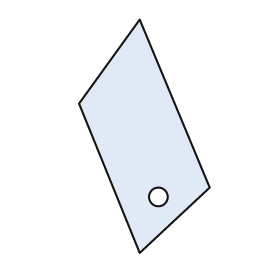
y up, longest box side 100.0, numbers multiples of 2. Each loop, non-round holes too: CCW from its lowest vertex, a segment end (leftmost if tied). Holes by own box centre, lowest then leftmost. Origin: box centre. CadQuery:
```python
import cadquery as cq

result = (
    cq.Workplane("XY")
    .moveTo(-2.0, -50.0)
    .lineTo(28.0, -22.0)
    .lineTo(-2.0, 50.0)
    .lineTo(-28.0, 14.0)
    .close()
    .moveTo(6.0, -26.0)
    .circle(4.0)
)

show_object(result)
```